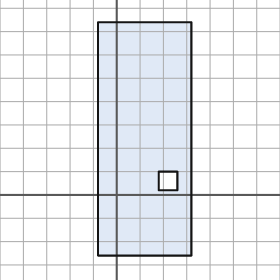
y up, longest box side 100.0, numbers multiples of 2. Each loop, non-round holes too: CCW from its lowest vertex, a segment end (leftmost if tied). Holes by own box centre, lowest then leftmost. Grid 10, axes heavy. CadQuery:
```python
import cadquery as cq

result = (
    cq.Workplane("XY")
    .moveTo(-8.0, -26.0)
    .lineTo(32.0, -26.0)
    .lineTo(32.0, 74.0)
    .lineTo(-8.0, 74.0)
    .close()
    .moveTo(18.0, 2.0)
    .lineTo(26.0, 2.0)
    .lineTo(26.0, 10.0)
    .lineTo(18.0, 10.0)
    .close()
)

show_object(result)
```